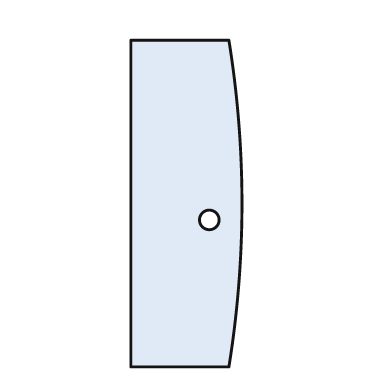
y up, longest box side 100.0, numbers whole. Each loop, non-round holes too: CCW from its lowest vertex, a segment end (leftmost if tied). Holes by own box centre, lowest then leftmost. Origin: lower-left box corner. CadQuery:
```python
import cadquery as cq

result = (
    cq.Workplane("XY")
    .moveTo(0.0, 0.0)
    .lineTo(30.0, 0.0)
    .threePointArc((34.0, 50.0), (30.0, 100.0))
    .lineTo(0.0, 100.0)
    .close()
    .moveTo(24.0, 45.0)
    .circle(3.0)
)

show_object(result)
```